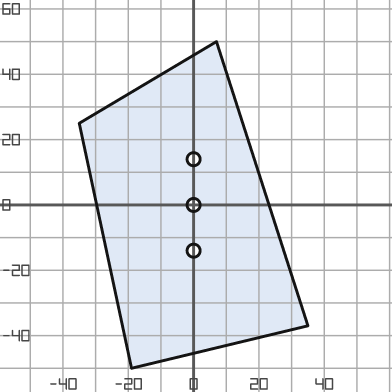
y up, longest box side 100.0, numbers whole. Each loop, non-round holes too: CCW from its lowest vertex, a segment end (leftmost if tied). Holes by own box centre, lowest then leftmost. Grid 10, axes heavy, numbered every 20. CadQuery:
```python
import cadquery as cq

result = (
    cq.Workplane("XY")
    .moveTo(-19.0, -50.0)
    .lineTo(35.0, -37.0)
    .lineTo(7.0, 50.0)
    .lineTo(-35.0, 25.0)
    .close()
    .moveTo(0.0, -14.0)
    .circle(2.0)
    .moveTo(0.0, 0.0)
    .circle(2.0)
    .moveTo(0.0, 14.0)
    .circle(2.0)
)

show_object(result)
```